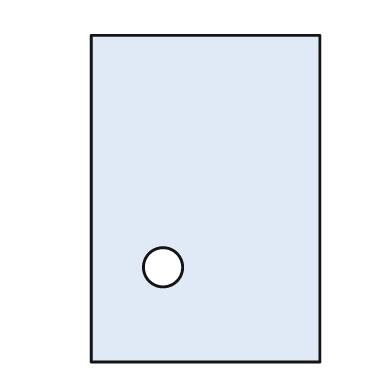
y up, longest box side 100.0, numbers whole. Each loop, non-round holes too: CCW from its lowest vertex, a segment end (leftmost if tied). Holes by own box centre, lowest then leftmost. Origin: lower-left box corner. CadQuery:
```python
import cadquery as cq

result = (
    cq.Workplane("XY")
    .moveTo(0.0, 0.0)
    .lineTo(70.0, 0.0)
    .lineTo(70.0, 100.0)
    .lineTo(0.0, 100.0)
    .close()
    .moveTo(22.0, 29.0)
    .circle(6.0)
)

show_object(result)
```